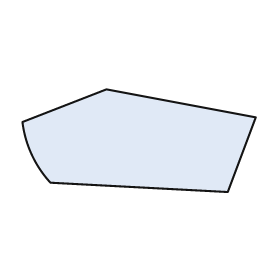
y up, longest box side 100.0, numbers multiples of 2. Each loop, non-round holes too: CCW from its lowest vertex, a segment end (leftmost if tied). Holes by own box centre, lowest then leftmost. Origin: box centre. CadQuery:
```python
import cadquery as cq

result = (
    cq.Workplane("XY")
    .moveTo(38.0, -22.0)
    .lineTo(50.0, 10.0)
    .lineTo(-14.0, 22.0)
    .lineTo(-50.0, 8.0)
    .threePointArc((-46.0, -6.0), (-38.0, -18.0))
    .close()
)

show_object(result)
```